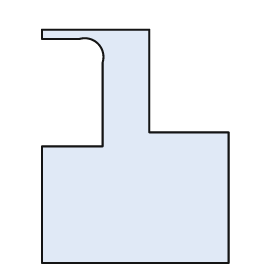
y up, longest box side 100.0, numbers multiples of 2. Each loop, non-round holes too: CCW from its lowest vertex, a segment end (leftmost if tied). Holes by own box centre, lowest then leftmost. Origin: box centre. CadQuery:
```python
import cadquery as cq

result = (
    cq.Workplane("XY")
    .moveTo(-40.0, -50.0)
    .lineTo(40.0, -50.0)
    .lineTo(40.0, 6.0)
    .lineTo(6.0, 6.0)
    .lineTo(6.0, 50.0)
    .lineTo(-40.0, 50.0)
    .lineTo(-40.0, 46.0)
    .lineTo(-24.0, 46.0)
    .threePointArc((-16.0, 44.0), (-14.0, 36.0))
    .lineTo(-14.0, 0.0)
    .lineTo(-40.0, 0.0)
    .close()
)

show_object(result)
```